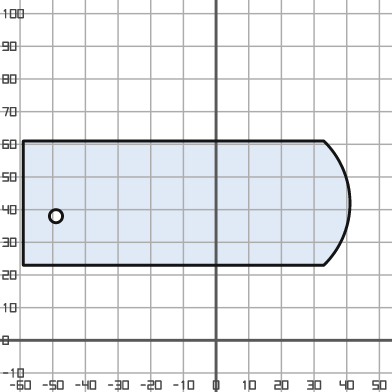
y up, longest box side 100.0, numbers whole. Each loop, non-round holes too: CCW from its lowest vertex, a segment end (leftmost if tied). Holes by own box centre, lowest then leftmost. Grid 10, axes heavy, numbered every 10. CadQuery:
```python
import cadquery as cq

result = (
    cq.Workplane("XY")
    .moveTo(-59.0, 23.0)
    .lineTo(33.0, 23.0)
    .threePointArc((41.0, 42.0), (33.0, 61.0))
    .lineTo(-59.0, 61.0)
    .close()
    .moveTo(-49.0, 38.0)
    .circle(2.0)
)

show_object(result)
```